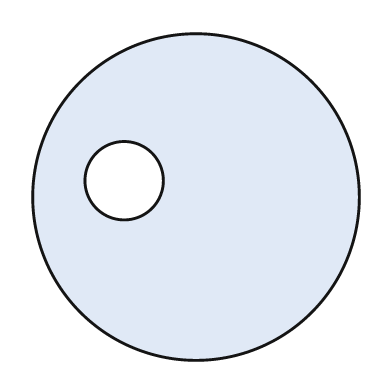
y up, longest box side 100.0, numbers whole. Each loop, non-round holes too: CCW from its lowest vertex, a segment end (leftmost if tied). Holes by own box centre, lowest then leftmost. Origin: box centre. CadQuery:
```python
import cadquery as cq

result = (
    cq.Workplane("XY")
    .moveTo(0.0, 0.0)
    .circle(50.0)
    .moveTo(-22.0, 5.0)
    .circle(12.0)
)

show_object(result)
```